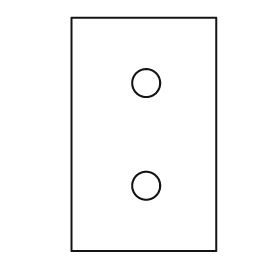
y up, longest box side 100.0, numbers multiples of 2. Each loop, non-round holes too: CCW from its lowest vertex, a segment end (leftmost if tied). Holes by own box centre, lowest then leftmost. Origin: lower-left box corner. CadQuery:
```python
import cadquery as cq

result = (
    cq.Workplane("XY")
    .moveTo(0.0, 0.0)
    .lineTo(62.0, 0.0)
    .lineTo(62.0, 100.0)
    .lineTo(0.0, 100.0)
    .close()
    .moveTo(32.0, 28.0)
    .circle(6.0)
    .moveTo(32.0, 72.0)
    .circle(6.0)
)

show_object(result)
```